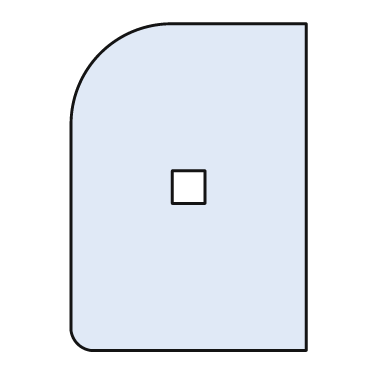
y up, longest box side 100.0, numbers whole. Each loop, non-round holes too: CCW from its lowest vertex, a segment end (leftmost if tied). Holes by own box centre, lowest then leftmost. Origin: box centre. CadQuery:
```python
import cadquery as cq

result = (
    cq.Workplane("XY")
    .moveTo(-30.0, -50.0)
    .lineTo(36.0, -50.0)
    .lineTo(36.0, 50.0)
    .lineTo(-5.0, 50.0)
    .threePointArc((-27.0, 41.0), (-36.0, 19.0))
    .lineTo(-36.0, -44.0)
    .threePointArc((-34.0, -48.0), (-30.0, -50.0))
    .close()
    .moveTo(-5.0, -5.0)
    .lineTo(5.0, -5.0)
    .lineTo(5.0, 5.0)
    .lineTo(-5.0, 5.0)
    .close()
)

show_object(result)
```